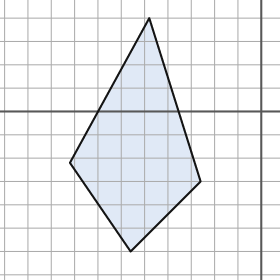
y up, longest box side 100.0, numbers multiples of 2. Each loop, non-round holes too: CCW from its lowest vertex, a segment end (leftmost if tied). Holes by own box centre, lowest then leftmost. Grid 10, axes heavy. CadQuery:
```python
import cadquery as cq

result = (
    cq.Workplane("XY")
    .moveTo(-56.0, -60.0)
    .lineTo(-26.0, -30.0)
    .lineTo(-48.0, 40.0)
    .lineTo(-82.0, -22.0)
    .close()
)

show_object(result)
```